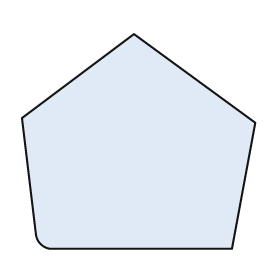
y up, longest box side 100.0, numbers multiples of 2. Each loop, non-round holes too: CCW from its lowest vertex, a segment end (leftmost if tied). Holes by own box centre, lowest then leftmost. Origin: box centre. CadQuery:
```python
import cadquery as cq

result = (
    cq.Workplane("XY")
    .moveTo(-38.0, -46.0)
    .lineTo(40.0, -46.0)
    .lineTo(50.0, 8.0)
    .lineTo(-2.0, 46.0)
    .lineTo(-50.0, 10.0)
    .lineTo(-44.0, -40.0)
    .threePointArc((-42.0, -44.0), (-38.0, -46.0))
    .close()
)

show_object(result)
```